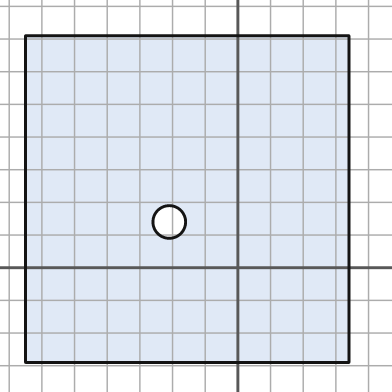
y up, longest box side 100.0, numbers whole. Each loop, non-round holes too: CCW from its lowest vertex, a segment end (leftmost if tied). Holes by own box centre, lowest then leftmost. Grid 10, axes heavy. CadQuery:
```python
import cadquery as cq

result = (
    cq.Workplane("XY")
    .moveTo(-65.0, -29.0)
    .lineTo(34.0, -29.0)
    .lineTo(34.0, 71.0)
    .lineTo(-65.0, 71.0)
    .close()
    .moveTo(-21.0, 14.0)
    .circle(5.0)
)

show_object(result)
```